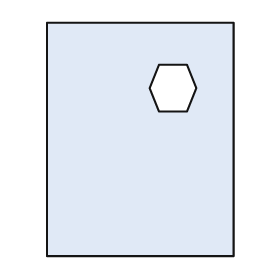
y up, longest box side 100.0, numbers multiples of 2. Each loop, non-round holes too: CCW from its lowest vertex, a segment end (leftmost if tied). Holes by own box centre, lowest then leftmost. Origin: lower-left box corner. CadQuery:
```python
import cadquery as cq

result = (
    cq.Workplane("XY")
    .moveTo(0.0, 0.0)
    .lineTo(80.0, 0.0)
    .lineTo(80.0, 100.0)
    .lineTo(0.0, 100.0)
    .close()
    .moveTo(48.0, 62.0)
    .lineTo(60.0, 62.0)
    .lineTo(64.0, 72.0)
    .lineTo(60.0, 82.0)
    .lineTo(48.0, 82.0)
    .lineTo(44.0, 72.0)
    .close()
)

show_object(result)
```